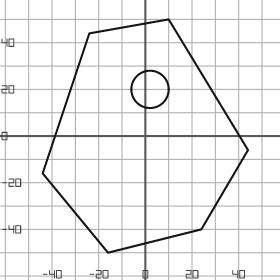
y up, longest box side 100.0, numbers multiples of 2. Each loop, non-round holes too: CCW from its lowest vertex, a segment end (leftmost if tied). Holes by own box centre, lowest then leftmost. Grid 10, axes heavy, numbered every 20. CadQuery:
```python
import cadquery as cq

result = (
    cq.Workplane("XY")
    .moveTo(-16.0, -50.0)
    .lineTo(24.0, -40.0)
    .lineTo(44.0, -6.0)
    .lineTo(10.0, 50.0)
    .lineTo(-24.0, 44.0)
    .lineTo(-44.0, -16.0)
    .close()
    .moveTo(2.0, 20.0)
    .circle(8.0)
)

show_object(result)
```